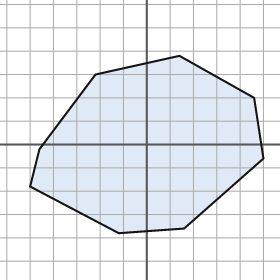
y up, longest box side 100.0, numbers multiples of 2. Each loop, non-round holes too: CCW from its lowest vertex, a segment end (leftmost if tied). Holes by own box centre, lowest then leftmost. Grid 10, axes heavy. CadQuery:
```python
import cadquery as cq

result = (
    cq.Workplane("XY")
    .moveTo(-12.0, -38.0)
    .lineTo(16.0, -36.0)
    .lineTo(50.0, -6.0)
    .lineTo(46.0, 20.0)
    .lineTo(14.0, 38.0)
    .lineTo(-22.0, 30.0)
    .lineTo(-46.0, -2.0)
    .lineTo(-50.0, -18.0)
    .close()
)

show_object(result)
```